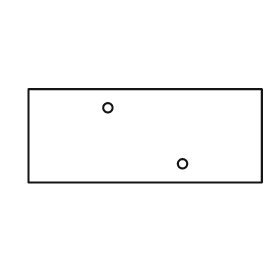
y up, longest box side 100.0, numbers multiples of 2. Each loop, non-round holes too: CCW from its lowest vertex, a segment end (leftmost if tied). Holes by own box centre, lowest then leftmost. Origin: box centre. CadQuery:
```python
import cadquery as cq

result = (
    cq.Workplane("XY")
    .moveTo(-50.0, -20.0)
    .lineTo(50.0, -20.0)
    .lineTo(50.0, 20.0)
    .lineTo(-50.0, 20.0)
    .close()
    .moveTo(16.0, -12.0)
    .circle(2.0)
    .moveTo(-16.0, 12.0)
    .circle(2.0)
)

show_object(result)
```